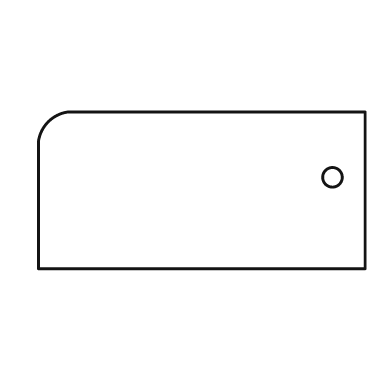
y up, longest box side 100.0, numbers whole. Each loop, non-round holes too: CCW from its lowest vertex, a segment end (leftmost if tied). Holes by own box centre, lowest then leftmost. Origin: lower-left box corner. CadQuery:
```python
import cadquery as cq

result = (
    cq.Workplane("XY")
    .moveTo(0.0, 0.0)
    .lineTo(100.0, 0.0)
    .lineTo(100.0, 48.0)
    .lineTo(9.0, 48.0)
    .threePointArc((3.0, 45.0), (0.0, 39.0))
    .close()
    .moveTo(90.0, 28.0)
    .circle(3.0)
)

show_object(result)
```